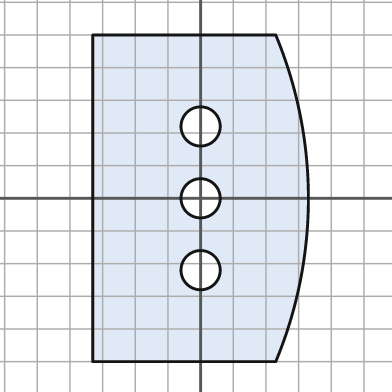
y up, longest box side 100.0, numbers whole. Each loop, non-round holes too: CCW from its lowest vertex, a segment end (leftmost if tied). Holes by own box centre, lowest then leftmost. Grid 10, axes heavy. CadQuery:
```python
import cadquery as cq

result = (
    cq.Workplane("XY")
    .moveTo(-33.0, -50.0)
    .lineTo(23.0, -50.0)
    .threePointArc((33.0, 0.0), (23.0, 50.0))
    .lineTo(-33.0, 50.0)
    .close()
    .moveTo(0.0, -22.0)
    .circle(6.0)
    .moveTo(0.0, 0.0)
    .circle(6.0)
    .moveTo(0.0, 22.0)
    .circle(6.0)
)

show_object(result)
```